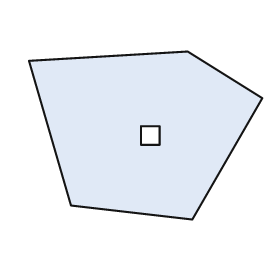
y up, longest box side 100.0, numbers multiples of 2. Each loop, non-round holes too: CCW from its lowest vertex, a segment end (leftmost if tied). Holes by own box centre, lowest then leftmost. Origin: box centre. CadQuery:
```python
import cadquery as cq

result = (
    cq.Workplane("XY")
    .moveTo(20.0, -36.0)
    .lineTo(50.0, 16.0)
    .lineTo(18.0, 36.0)
    .lineTo(-50.0, 32.0)
    .lineTo(-32.0, -30.0)
    .close()
    .moveTo(-2.0, -4.0)
    .lineTo(6.0, -4.0)
    .lineTo(6.0, 4.0)
    .lineTo(-2.0, 4.0)
    .close()
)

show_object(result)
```